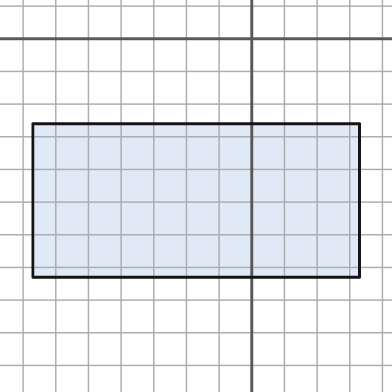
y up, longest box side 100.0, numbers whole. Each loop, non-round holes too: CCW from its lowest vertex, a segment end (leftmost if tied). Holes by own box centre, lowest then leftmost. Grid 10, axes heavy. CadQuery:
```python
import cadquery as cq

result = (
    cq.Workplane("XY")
    .moveTo(-67.0, -73.0)
    .lineTo(33.0, -73.0)
    .lineTo(33.0, -26.0)
    .lineTo(-67.0, -26.0)
    .close()
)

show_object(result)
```